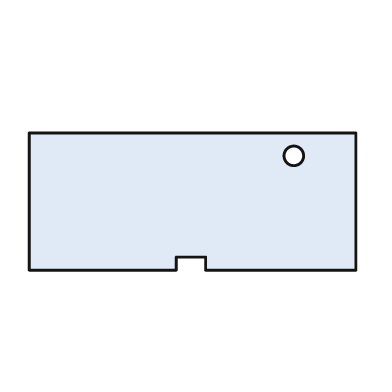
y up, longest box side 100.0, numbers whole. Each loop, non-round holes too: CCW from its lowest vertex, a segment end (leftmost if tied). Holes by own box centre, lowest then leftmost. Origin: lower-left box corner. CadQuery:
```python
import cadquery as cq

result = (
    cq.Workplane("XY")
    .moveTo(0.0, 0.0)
    .lineTo(45.0, 0.0)
    .lineTo(45.0, 4.0)
    .lineTo(54.0, 4.0)
    .lineTo(54.0, 0.0)
    .lineTo(100.0, 0.0)
    .lineTo(100.0, 42.0)
    .lineTo(0.0, 42.0)
    .close()
    .moveTo(81.0, 35.0)
    .circle(3.0)
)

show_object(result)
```